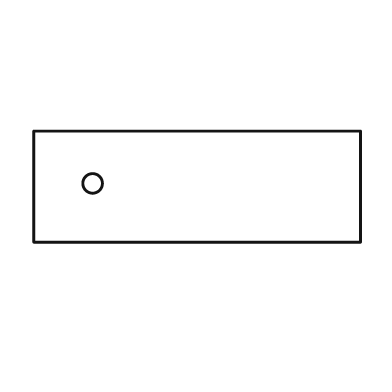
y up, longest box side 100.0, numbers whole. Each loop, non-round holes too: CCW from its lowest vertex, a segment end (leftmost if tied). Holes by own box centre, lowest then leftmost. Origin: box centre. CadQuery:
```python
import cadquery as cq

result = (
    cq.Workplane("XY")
    .moveTo(-50.0, -17.0)
    .lineTo(50.0, -17.0)
    .lineTo(50.0, 17.0)
    .lineTo(-50.0, 17.0)
    .close()
    .moveTo(-32.0, 1.0)
    .circle(3.0)
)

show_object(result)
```